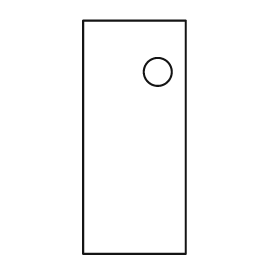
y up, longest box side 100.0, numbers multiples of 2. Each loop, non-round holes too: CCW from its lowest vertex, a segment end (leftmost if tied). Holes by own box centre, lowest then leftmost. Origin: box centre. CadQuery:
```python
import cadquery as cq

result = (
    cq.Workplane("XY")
    .moveTo(-22.0, -50.0)
    .lineTo(22.0, -50.0)
    .lineTo(22.0, 50.0)
    .lineTo(-22.0, 50.0)
    .close()
    .moveTo(10.0, 28.0)
    .circle(6.0)
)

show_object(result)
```